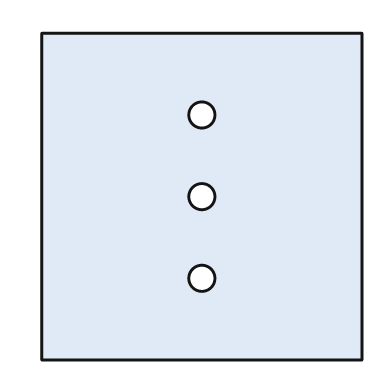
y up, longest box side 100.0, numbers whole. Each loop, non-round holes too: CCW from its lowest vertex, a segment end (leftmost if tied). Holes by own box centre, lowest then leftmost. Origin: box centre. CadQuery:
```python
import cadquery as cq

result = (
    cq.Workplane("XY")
    .moveTo(-49.0, -50.0)
    .lineTo(49.0, -50.0)
    .lineTo(49.0, 50.0)
    .lineTo(-49.0, 50.0)
    .close()
    .moveTo(0.0, -25.0)
    .circle(4.0)
    .moveTo(0.0, 0.0)
    .circle(4.0)
    .moveTo(0.0, 25.0)
    .circle(4.0)
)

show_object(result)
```